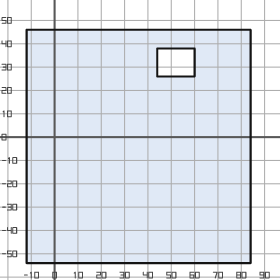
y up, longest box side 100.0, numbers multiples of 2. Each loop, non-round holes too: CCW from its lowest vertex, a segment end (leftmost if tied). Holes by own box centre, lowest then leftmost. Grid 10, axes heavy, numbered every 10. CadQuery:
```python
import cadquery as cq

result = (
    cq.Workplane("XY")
    .moveTo(-12.0, -54.0)
    .lineTo(84.0, -54.0)
    .lineTo(84.0, 46.0)
    .lineTo(-12.0, 46.0)
    .close()
    .moveTo(44.0, 26.0)
    .lineTo(60.0, 26.0)
    .lineTo(60.0, 38.0)
    .lineTo(44.0, 38.0)
    .close()
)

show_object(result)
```